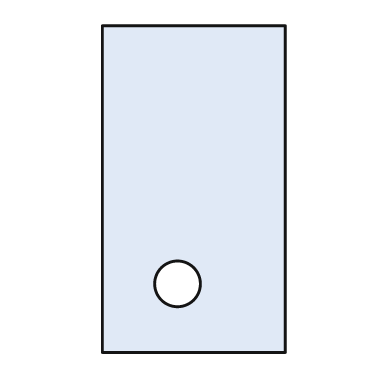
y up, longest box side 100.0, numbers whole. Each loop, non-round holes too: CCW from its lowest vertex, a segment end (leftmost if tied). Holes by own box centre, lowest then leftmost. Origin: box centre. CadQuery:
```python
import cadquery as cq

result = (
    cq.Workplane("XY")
    .moveTo(-28.0, -50.0)
    .lineTo(28.0, -50.0)
    .lineTo(28.0, 50.0)
    .lineTo(-28.0, 50.0)
    .close()
    .moveTo(-5.0, -29.0)
    .circle(7.0)
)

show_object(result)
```